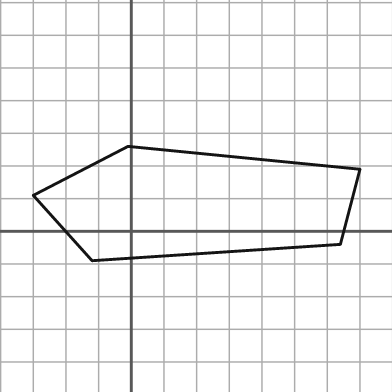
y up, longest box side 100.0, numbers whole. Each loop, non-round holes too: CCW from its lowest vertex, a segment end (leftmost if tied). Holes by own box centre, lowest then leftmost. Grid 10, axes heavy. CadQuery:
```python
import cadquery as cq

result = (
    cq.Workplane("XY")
    .moveTo(-12.0, -9.0)
    .lineTo(64.0, -4.0)
    .lineTo(70.0, 19.0)
    .lineTo(-1.0, 26.0)
    .lineTo(-30.0, 11.0)
    .close()
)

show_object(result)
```